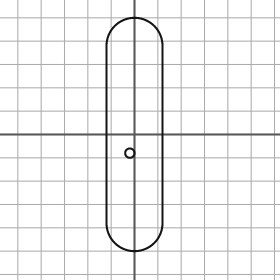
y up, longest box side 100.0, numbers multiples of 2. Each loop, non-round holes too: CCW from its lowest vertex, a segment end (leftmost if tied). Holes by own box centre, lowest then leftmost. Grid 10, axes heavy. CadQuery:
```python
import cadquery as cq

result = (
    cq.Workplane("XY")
    .moveTo(-12.0, -38.0)
    .threePointArc((0.0, -50.0), (12.0, -38.0))
    .lineTo(12.0, 38.0)
    .threePointArc((0.0, 50.0), (-12.0, 38.0))
    .close()
    .moveTo(-2.0, -8.0)
    .circle(2.0)
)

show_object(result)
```